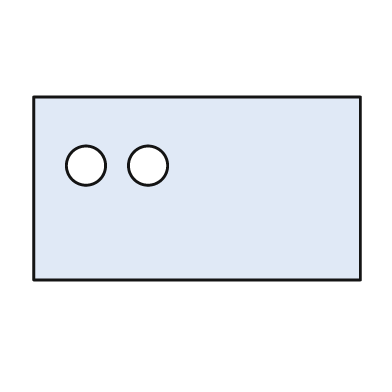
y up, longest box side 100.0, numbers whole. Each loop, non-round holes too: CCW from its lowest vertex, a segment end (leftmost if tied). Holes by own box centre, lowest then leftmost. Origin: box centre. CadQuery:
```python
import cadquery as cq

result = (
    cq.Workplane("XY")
    .moveTo(-50.0, -28.0)
    .lineTo(50.0, -28.0)
    .lineTo(50.0, 28.0)
    .lineTo(-50.0, 28.0)
    .close()
    .moveTo(-34.0, 7.0)
    .circle(6.0)
    .moveTo(-15.0, 7.0)
    .circle(6.0)
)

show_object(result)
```